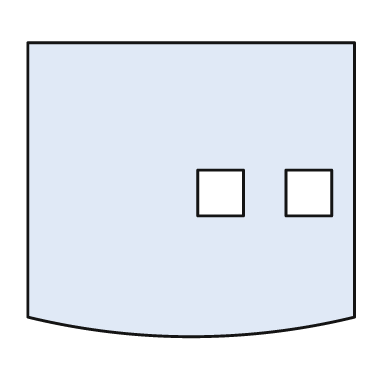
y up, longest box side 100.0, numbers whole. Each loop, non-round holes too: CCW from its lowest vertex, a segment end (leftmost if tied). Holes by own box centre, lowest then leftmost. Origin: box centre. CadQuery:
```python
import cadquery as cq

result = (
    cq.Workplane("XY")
    .moveTo(-50.0, -39.0)
    .threePointArc((0.0, -45.0), (50.0, -39.0))
    .lineTo(50.0, 45.0)
    .lineTo(-50.0, 45.0)
    .close()
    .moveTo(2.0, -8.0)
    .lineTo(16.0, -8.0)
    .lineTo(16.0, 6.0)
    .lineTo(2.0, 6.0)
    .close()
    .moveTo(29.0, -8.0)
    .lineTo(43.0, -8.0)
    .lineTo(43.0, 6.0)
    .lineTo(29.0, 6.0)
    .close()
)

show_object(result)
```